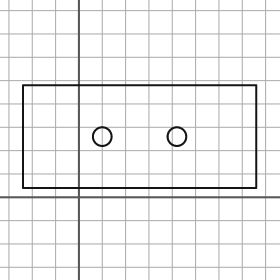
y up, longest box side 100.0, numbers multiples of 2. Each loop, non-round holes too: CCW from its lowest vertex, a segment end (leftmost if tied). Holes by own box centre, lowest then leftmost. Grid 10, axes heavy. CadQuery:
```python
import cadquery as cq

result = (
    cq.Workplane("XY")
    .moveTo(-24.0, 4.0)
    .lineTo(76.0, 4.0)
    .lineTo(76.0, 48.0)
    .lineTo(-24.0, 48.0)
    .close()
    .moveTo(10.0, 26.0)
    .circle(4.0)
    .moveTo(42.0, 26.0)
    .circle(4.0)
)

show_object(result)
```